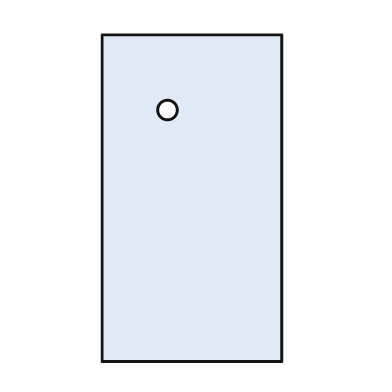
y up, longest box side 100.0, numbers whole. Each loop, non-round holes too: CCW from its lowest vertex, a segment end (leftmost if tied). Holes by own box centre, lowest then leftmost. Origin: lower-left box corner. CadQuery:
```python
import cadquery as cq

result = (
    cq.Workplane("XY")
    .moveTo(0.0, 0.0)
    .lineTo(55.0, 0.0)
    .lineTo(55.0, 100.0)
    .lineTo(0.0, 100.0)
    .close()
    .moveTo(20.0, 77.0)
    .circle(3.0)
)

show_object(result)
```